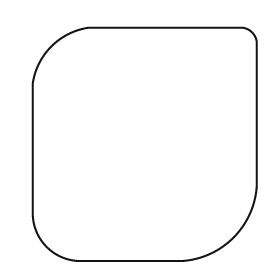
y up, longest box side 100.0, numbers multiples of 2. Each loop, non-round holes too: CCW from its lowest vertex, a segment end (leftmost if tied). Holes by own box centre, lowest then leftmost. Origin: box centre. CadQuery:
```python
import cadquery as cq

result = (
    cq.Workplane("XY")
    .moveTo(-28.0, -50.0)
    .lineTo(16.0, -50.0)
    .threePointArc((38.0, -40.0), (48.0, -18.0))
    .lineTo(48.0, 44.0)
    .threePointArc((46.0, 48.0), (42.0, 50.0))
    .lineTo(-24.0, 50.0)
    .threePointArc((-40.0, 42.0), (-48.0, 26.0))
    .lineTo(-48.0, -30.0)
    .threePointArc((-42.0, -44.0), (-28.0, -50.0))
    .close()
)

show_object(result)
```